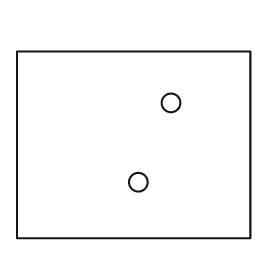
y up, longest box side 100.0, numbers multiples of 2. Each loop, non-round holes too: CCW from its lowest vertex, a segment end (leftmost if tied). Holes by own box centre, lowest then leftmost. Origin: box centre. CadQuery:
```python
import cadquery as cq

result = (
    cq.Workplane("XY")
    .moveTo(-50.0, -40.0)
    .lineTo(50.0, -40.0)
    .lineTo(50.0, 40.0)
    .lineTo(-50.0, 40.0)
    .close()
    .moveTo(2.0, -16.0)
    .circle(4.0)
    .moveTo(16.0, 18.0)
    .circle(4.0)
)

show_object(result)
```